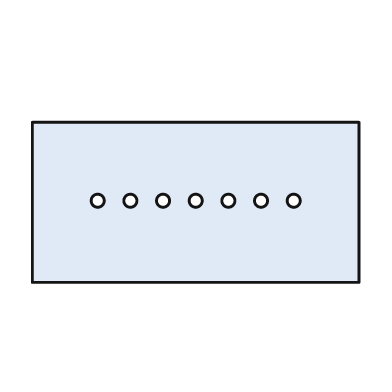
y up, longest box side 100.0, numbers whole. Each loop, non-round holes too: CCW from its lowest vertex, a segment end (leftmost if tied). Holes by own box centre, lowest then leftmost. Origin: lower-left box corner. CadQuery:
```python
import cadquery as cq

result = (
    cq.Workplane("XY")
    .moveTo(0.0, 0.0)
    .lineTo(100.0, 0.0)
    .lineTo(100.0, 49.0)
    .lineTo(0.0, 49.0)
    .close()
    .moveTo(20.0, 25.0)
    .circle(2.0)
    .moveTo(30.0, 25.0)
    .circle(2.0)
    .moveTo(40.0, 25.0)
    .circle(2.0)
    .moveTo(50.0, 25.0)
    .circle(2.0)
    .moveTo(60.0, 25.0)
    .circle(2.0)
    .moveTo(70.0, 25.0)
    .circle(2.0)
    .moveTo(80.0, 25.0)
    .circle(2.0)
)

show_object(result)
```